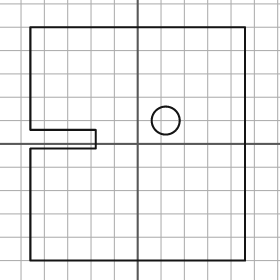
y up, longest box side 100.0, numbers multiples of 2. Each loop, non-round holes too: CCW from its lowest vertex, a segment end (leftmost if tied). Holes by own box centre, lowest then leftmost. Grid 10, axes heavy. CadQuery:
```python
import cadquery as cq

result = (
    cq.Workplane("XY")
    .moveTo(-46.0, -50.0)
    .lineTo(46.0, -50.0)
    .lineTo(46.0, 50.0)
    .lineTo(-46.0, 50.0)
    .lineTo(-46.0, 6.0)
    .lineTo(-18.0, 6.0)
    .lineTo(-18.0, -2.0)
    .lineTo(-46.0, -2.0)
    .close()
    .moveTo(12.0, 10.0)
    .circle(6.0)
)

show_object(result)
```